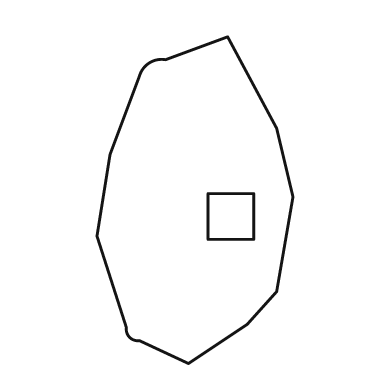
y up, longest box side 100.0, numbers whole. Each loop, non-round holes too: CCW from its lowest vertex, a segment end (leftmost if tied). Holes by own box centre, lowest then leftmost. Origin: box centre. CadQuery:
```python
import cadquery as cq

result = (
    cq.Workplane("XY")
    .moveTo(-2.0, -50.0)
    .lineTo(16.0, -38.0)
    .lineTo(25.0, -28.0)
    .lineTo(30.0, 1.0)
    .lineTo(25.0, 22.0)
    .lineTo(10.0, 50.0)
    .lineTo(-9.0, 43.0)
    .threePointArc((-14.0, 42.0), (-17.0, 38.0))
    .lineTo(-26.0, 14.0)
    .lineTo(-30.0, -11.0)
    .lineTo(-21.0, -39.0)
    .threePointArc((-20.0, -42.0), (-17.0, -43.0))
    .close()
    .moveTo(4.0, -12.0)
    .lineTo(18.0, -12.0)
    .lineTo(18.0, 2.0)
    .lineTo(4.0, 2.0)
    .close()
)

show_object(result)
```